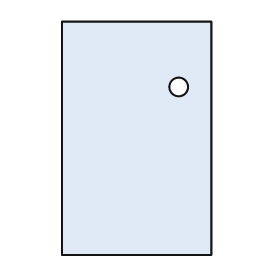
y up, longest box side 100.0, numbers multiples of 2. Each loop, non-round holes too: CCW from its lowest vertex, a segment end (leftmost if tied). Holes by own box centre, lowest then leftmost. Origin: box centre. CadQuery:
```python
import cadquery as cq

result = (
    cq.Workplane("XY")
    .moveTo(-32.0, -50.0)
    .lineTo(32.0, -50.0)
    .lineTo(32.0, 50.0)
    .lineTo(-32.0, 50.0)
    .close()
    .moveTo(18.0, 22.0)
    .circle(4.0)
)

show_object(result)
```